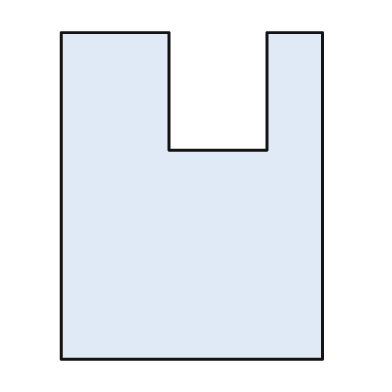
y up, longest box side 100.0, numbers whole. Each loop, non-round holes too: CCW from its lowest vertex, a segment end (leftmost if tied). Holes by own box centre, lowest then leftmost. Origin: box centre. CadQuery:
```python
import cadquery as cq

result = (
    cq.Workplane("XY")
    .moveTo(-40.0, -50.0)
    .lineTo(40.0, -50.0)
    .lineTo(40.0, 50.0)
    .lineTo(23.0, 50.0)
    .lineTo(23.0, 14.0)
    .lineTo(-7.0, 14.0)
    .lineTo(-7.0, 50.0)
    .lineTo(-40.0, 50.0)
    .close()
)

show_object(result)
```